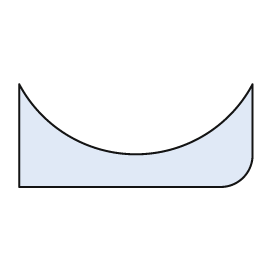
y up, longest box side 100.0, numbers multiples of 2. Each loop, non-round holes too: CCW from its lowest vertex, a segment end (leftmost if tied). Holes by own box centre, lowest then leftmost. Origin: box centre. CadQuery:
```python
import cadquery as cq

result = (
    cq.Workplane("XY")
    .moveTo(-50.0, -22.0)
    .lineTo(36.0, -22.0)
    .threePointArc((46.0, -18.0), (50.0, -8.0))
    .lineTo(50.0, 22.0)
    .threePointArc((0.0, -8.0), (-50.0, 22.0))
    .close()
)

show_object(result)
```